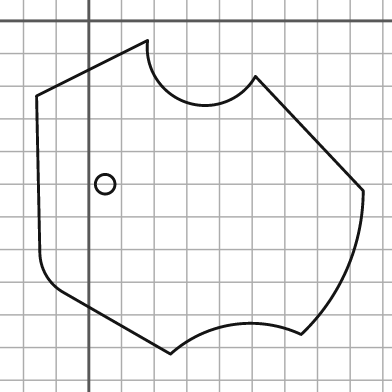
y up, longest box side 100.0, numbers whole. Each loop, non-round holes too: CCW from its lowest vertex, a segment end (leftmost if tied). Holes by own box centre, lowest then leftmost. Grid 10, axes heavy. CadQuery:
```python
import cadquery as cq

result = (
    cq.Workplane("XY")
    .moveTo(25.0, -102.0)
    .threePointArc((44.0, -93.0), (65.0, -96.0))
    .threePointArc((79.0, -76.0), (84.0, -52.0))
    .lineTo(51.0, -17.0)
    .threePointArc((30.0, -25.0), (18.0, -6.0))
    .lineTo(-16.0, -23.0)
    .lineTo(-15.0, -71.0)
    .threePointArc((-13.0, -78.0), (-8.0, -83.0))
    .close()
    .moveTo(5.0, -50.0)
    .circle(3.0)
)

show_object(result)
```